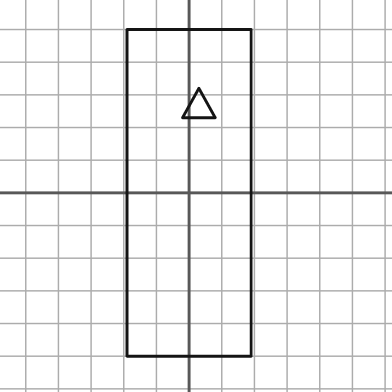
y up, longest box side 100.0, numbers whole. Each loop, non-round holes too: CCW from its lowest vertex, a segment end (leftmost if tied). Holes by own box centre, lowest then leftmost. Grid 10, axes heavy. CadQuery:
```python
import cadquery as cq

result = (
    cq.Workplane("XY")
    .moveTo(-19.0, -50.0)
    .lineTo(19.0, -50.0)
    .lineTo(19.0, 50.0)
    .lineTo(-19.0, 50.0)
    .close()
    .moveTo(-2.0, 23.0)
    .lineTo(8.0, 23.0)
    .lineTo(3.0, 32.0)
    .close()
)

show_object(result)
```